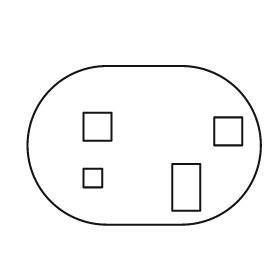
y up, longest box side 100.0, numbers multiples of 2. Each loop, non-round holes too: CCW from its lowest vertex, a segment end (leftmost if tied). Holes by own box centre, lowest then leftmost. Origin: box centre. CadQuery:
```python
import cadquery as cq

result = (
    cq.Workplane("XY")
    .moveTo(-16.0, -34.0)
    .lineTo(16.0, -34.0)
    .threePointArc((50.0, 0.0), (16.0, 34.0))
    .lineTo(-16.0, 34.0)
    .threePointArc((-50.0, 0.0), (-16.0, -34.0))
    .close()
    .moveTo(12.0, -28.0)
    .lineTo(24.0, -28.0)
    .lineTo(24.0, -8.0)
    .lineTo(12.0, -8.0)
    .close()
    .moveTo(-26.0, -18.0)
    .lineTo(-18.0, -18.0)
    .lineTo(-18.0, -10.0)
    .lineTo(-26.0, -10.0)
    .close()
    .moveTo(30.0, 0.0)
    .lineTo(42.0, 0.0)
    .lineTo(42.0, 12.0)
    .lineTo(30.0, 12.0)
    .close()
    .moveTo(-26.0, 2.0)
    .lineTo(-14.0, 2.0)
    .lineTo(-14.0, 14.0)
    .lineTo(-26.0, 14.0)
    .close()
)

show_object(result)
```